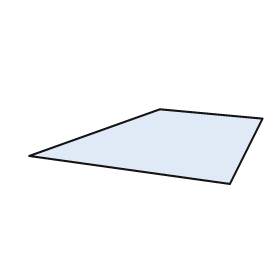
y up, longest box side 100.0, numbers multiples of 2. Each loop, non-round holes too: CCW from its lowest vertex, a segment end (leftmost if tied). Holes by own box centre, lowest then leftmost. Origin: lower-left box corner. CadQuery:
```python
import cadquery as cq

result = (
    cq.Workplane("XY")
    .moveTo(86.0, 0.0)
    .lineTo(100.0, 28.0)
    .lineTo(56.0, 32.0)
    .lineTo(0.0, 12.0)
    .close()
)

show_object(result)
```